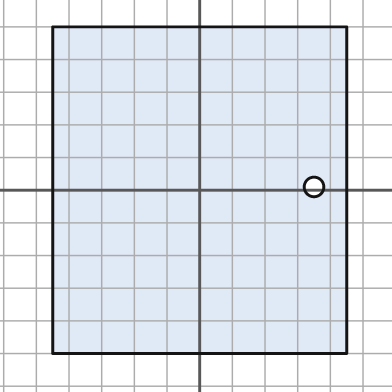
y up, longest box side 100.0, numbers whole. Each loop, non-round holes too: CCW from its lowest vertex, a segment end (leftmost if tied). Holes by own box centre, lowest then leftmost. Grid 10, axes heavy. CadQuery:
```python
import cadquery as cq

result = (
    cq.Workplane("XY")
    .moveTo(-45.0, -50.0)
    .lineTo(45.0, -50.0)
    .lineTo(45.0, 50.0)
    .lineTo(-45.0, 50.0)
    .close()
    .moveTo(35.0, 1.0)
    .circle(3.0)
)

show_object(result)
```